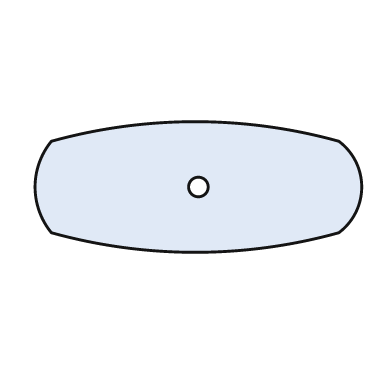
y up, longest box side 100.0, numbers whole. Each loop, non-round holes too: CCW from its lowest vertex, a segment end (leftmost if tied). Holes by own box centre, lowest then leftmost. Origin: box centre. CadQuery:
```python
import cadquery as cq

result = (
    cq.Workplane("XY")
    .moveTo(-45.0, -14.0)
    .threePointArc((-1.0, -20.0), (43.0, -14.0))
    .threePointArc((50.0, 0.0), (43.0, 14.0))
    .threePointArc((-1.0, 20.0), (-45.0, 14.0))
    .threePointArc((-50.0, 0.0), (-45.0, -14.0))
    .close()
    .moveTo(0.0, 0.0)
    .circle(3.0)
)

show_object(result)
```